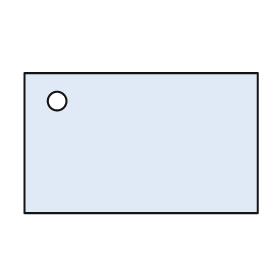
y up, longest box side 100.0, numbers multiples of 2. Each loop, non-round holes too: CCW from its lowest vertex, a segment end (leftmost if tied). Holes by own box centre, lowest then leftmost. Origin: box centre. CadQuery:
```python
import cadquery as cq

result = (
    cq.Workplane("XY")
    .moveTo(-50.0, -30.0)
    .lineTo(50.0, -30.0)
    .lineTo(50.0, 30.0)
    .lineTo(-50.0, 30.0)
    .close()
    .moveTo(-36.0, 18.0)
    .circle(4.0)
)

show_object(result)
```